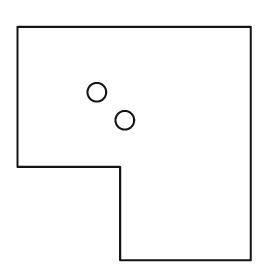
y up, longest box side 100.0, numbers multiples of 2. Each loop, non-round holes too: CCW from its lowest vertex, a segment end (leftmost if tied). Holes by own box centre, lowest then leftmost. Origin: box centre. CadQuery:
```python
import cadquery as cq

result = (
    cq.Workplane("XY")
    .moveTo(-6.0, -50.0)
    .lineTo(50.0, -50.0)
    .lineTo(50.0, 50.0)
    .lineTo(-50.0, 50.0)
    .lineTo(-50.0, -10.0)
    .lineTo(-6.0, -10.0)
    .close()
    .moveTo(-4.0, 10.0)
    .circle(4.0)
    .moveTo(-16.0, 22.0)
    .circle(4.0)
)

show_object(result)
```